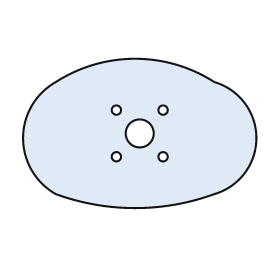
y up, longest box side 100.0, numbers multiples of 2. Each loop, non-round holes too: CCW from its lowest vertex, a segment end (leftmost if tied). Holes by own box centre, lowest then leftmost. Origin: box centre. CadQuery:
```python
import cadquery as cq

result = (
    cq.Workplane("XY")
    .moveTo(-36.0, -26.0)
    .threePointArc((-2.0, -32.0), (32.0, -26.0))
    .threePointArc((50.0, -2.0), (32.0, 22.0))
    .threePointArc((-2.0, 32.0), (-36.0, 22.0))
    .threePointArc((-50.0, -2.0), (-36.0, -26.0))
    .close()
    .moveTo(-10.0, -10.0)
    .circle(2.0)
    .moveTo(10.0, -10.0)
    .circle(2.0)
    .moveTo(0.0, 0.0)
    .circle(6.0)
    .moveTo(-10.0, 10.0)
    .circle(2.0)
    .moveTo(10.0, 10.0)
    .circle(2.0)
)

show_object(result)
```